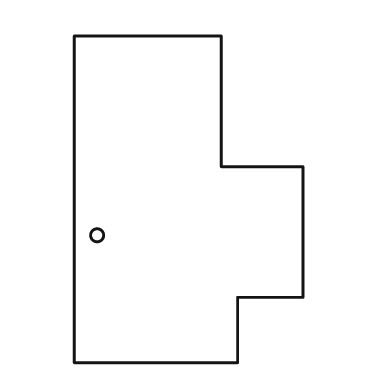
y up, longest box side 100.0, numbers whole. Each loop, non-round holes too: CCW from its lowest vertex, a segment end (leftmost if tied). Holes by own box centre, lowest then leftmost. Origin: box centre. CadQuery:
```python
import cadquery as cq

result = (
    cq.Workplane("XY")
    .moveTo(-35.0, -50.0)
    .lineTo(15.0, -50.0)
    .lineTo(15.0, -30.0)
    .lineTo(35.0, -30.0)
    .lineTo(35.0, 10.0)
    .lineTo(10.0, 10.0)
    .lineTo(10.0, 50.0)
    .lineTo(-35.0, 50.0)
    .close()
    .moveTo(-28.0, -11.0)
    .circle(2.0)
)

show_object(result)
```